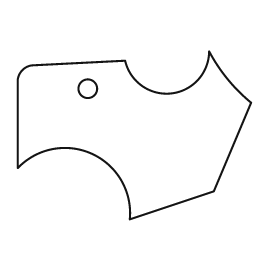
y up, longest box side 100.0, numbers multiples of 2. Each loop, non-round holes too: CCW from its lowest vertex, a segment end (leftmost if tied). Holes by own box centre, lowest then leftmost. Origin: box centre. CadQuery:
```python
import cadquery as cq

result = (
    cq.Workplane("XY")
    .moveTo(-2.0, -36.0)
    .lineTo(34.0, -24.0)
    .lineTo(50.0, 14.0)
    .threePointArc((40.0, 24.0), (32.0, 36.0))
    .threePointArc((16.0, 18.0), (-4.0, 32.0))
    .lineTo(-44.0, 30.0)
    .threePointArc((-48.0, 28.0), (-50.0, 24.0))
    .lineTo(-50.0, -14.0)
    .threePointArc((-18.0, -8.0), (-2.0, -36.0))
    .close()
    .moveTo(-20.0, 20.0)
    .circle(4.0)
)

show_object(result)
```